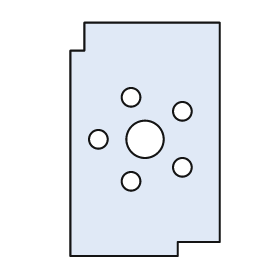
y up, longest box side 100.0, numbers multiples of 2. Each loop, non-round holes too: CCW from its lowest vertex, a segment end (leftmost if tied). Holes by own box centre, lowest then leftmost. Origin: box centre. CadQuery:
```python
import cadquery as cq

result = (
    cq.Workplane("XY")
    .moveTo(-32.0, -50.0)
    .lineTo(14.0, -50.0)
    .lineTo(14.0, -44.0)
    .lineTo(32.0, -44.0)
    .lineTo(32.0, 50.0)
    .lineTo(-26.0, 50.0)
    .lineTo(-26.0, 38.0)
    .lineTo(-32.0, 38.0)
    .close()
    .moveTo(-6.0, -18.0)
    .circle(4.0)
    .moveTo(16.0, -12.0)
    .circle(4.0)
    .moveTo(-20.0, 0.0)
    .circle(4.0)
    .moveTo(0.0, 0.0)
    .circle(8.0)
    .moveTo(16.0, 12.0)
    .circle(4.0)
    .moveTo(-6.0, 18.0)
    .circle(4.0)
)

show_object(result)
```